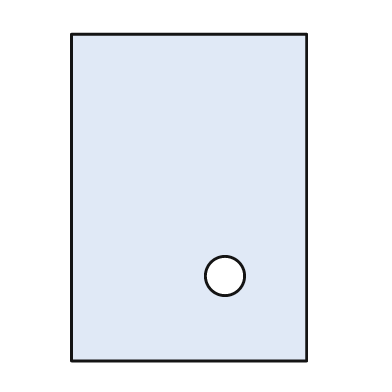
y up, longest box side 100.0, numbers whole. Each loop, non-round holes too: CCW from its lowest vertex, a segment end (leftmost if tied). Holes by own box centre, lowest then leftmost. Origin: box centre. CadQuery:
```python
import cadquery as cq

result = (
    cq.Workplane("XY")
    .moveTo(-36.0, -50.0)
    .lineTo(36.0, -50.0)
    .lineTo(36.0, 50.0)
    .lineTo(-36.0, 50.0)
    .close()
    .moveTo(11.0, -24.0)
    .circle(6.0)
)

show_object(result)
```